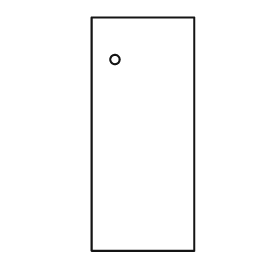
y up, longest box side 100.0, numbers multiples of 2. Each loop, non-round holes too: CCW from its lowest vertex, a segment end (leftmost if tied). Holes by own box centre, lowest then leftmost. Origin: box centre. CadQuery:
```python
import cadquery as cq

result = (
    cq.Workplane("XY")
    .moveTo(-22.0, -50.0)
    .lineTo(22.0, -50.0)
    .lineTo(22.0, 50.0)
    .lineTo(-22.0, 50.0)
    .close()
    .moveTo(-12.0, 32.0)
    .circle(2.0)
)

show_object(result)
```